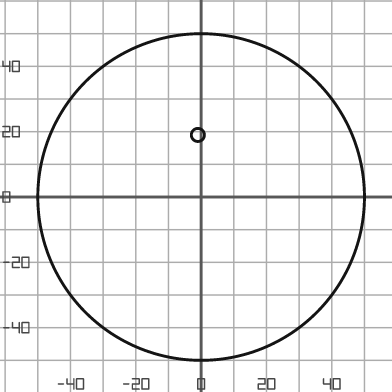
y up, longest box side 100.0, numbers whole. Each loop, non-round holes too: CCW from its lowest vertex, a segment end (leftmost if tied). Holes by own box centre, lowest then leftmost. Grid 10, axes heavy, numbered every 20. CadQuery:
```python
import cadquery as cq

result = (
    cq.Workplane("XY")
    .moveTo(0.0, 0.0)
    .circle(50.0)
    .moveTo(-1.0, 19.0)
    .circle(2.0)
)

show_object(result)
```